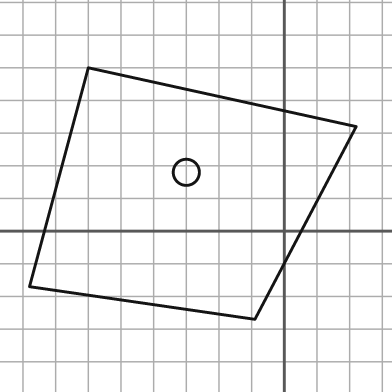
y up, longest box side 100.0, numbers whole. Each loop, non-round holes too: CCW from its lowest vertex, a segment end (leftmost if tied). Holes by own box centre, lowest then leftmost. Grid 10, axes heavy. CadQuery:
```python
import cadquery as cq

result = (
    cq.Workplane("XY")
    .moveTo(-9.0, -27.0)
    .lineTo(22.0, 32.0)
    .lineTo(-60.0, 50.0)
    .lineTo(-78.0, -17.0)
    .close()
    .moveTo(-30.0, 18.0)
    .circle(4.0)
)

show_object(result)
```